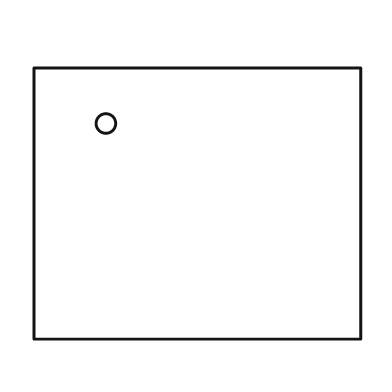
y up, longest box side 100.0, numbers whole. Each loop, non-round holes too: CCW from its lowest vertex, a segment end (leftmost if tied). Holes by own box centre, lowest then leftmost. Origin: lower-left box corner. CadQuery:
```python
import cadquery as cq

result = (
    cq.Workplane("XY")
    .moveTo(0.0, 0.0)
    .lineTo(100.0, 0.0)
    .lineTo(100.0, 83.0)
    .lineTo(0.0, 83.0)
    .close()
    .moveTo(22.0, 66.0)
    .circle(3.0)
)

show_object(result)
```